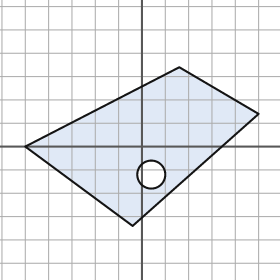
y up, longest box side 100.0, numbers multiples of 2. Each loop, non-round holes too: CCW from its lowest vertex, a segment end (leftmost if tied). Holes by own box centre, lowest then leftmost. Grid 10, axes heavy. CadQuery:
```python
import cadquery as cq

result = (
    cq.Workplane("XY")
    .moveTo(-4.0, -34.0)
    .lineTo(50.0, 14.0)
    .lineTo(16.0, 34.0)
    .lineTo(-50.0, 0.0)
    .close()
    .moveTo(4.0, -12.0)
    .circle(6.0)
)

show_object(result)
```